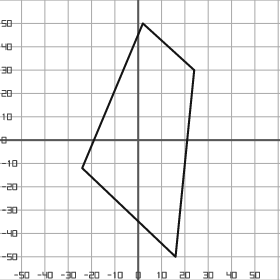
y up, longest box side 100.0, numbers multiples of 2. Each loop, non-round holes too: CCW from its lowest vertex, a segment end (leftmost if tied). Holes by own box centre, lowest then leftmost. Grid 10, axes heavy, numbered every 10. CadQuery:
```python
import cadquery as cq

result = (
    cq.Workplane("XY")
    .moveTo(16.0, -50.0)
    .lineTo(24.0, 30.0)
    .lineTo(2.0, 50.0)
    .lineTo(-24.0, -12.0)
    .close()
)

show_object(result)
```